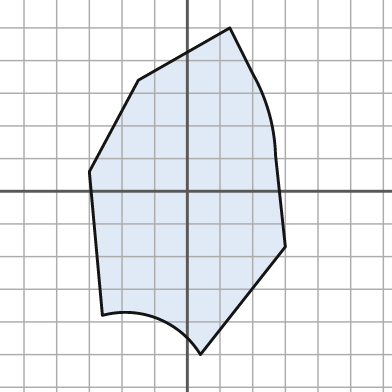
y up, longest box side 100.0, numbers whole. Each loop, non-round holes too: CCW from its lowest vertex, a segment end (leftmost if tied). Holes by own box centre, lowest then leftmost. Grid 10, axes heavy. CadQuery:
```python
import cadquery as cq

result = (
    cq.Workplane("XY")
    .moveTo(4.0, -50.0)
    .lineTo(30.0, -17.0)
    .lineTo(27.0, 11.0)
    .threePointArc((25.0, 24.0), (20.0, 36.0))
    .lineTo(13.0, 50.0)
    .lineTo(-15.0, 34.0)
    .lineTo(-30.0, 6.0)
    .lineTo(-26.0, -38.0)
    .threePointArc((-9.0, -39.0), (4.0, -50.0))
    .close()
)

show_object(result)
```